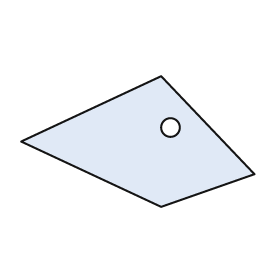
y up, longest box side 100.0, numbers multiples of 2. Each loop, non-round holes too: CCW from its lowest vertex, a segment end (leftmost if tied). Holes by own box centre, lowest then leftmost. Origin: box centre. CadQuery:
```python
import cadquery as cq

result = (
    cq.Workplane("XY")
    .moveTo(10.0, -28.0)
    .lineTo(50.0, -14.0)
    .lineTo(10.0, 28.0)
    .lineTo(-50.0, 0.0)
    .close()
    .moveTo(14.0, 6.0)
    .circle(4.0)
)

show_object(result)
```